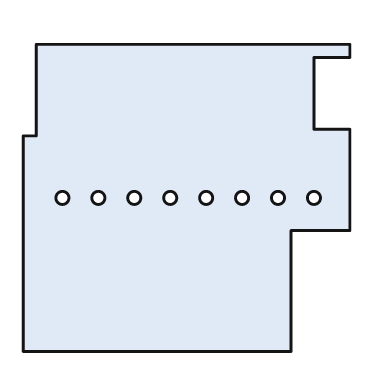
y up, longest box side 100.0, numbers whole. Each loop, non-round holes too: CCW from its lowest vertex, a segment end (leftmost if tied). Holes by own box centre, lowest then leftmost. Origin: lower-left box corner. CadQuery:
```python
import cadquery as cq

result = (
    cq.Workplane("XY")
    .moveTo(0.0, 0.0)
    .lineTo(82.0, 0.0)
    .lineTo(82.0, 37.0)
    .lineTo(100.0, 37.0)
    .lineTo(100.0, 68.0)
    .lineTo(89.0, 68.0)
    .lineTo(89.0, 90.0)
    .lineTo(100.0, 90.0)
    .lineTo(100.0, 94.0)
    .lineTo(4.0, 94.0)
    .lineTo(4.0, 66.0)
    .lineTo(0.0, 66.0)
    .close()
    .moveTo(12.0, 47.0)
    .circle(2.0)
    .moveTo(23.0, 47.0)
    .circle(2.0)
    .moveTo(34.0, 47.0)
    .circle(2.0)
    .moveTo(45.0, 47.0)
    .circle(2.0)
    .moveTo(56.0, 47.0)
    .circle(2.0)
    .moveTo(67.0, 47.0)
    .circle(2.0)
    .moveTo(78.0, 47.0)
    .circle(2.0)
    .moveTo(89.0, 47.0)
    .circle(2.0)
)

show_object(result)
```